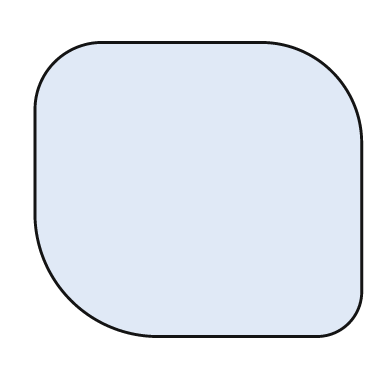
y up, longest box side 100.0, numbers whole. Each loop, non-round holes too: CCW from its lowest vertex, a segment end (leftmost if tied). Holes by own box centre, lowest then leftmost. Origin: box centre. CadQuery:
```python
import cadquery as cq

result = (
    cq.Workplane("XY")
    .moveTo(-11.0, -45.0)
    .lineTo(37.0, -45.0)
    .threePointArc((46.0, -41.0), (50.0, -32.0))
    .lineTo(50.0, 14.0)
    .threePointArc((41.0, 36.0), (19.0, 45.0))
    .lineTo(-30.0, 45.0)
    .threePointArc((-44.0, 39.0), (-50.0, 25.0))
    .lineTo(-50.0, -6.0)
    .threePointArc((-39.0, -34.0), (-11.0, -45.0))
    .close()
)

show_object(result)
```